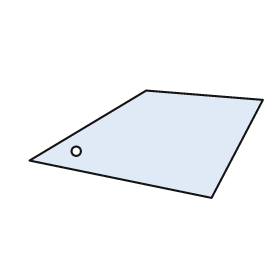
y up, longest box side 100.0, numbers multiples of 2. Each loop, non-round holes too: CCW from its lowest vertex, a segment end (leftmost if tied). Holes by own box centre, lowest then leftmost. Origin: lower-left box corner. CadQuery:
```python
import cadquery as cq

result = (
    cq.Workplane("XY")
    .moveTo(78.0, 0.0)
    .lineTo(100.0, 42.0)
    .lineTo(50.0, 46.0)
    .lineTo(0.0, 16.0)
    .close()
    .moveTo(20.0, 20.0)
    .circle(2.0)
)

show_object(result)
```